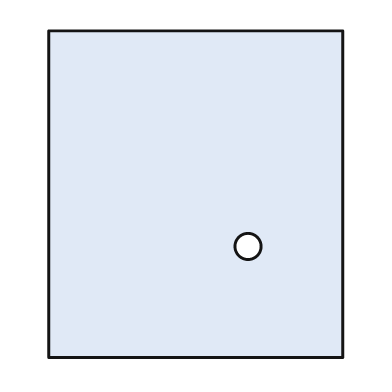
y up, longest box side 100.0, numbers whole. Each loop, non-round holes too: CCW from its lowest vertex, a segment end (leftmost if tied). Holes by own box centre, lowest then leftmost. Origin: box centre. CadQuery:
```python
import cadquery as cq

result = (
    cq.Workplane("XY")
    .moveTo(-45.0, -50.0)
    .lineTo(45.0, -50.0)
    .lineTo(45.0, 50.0)
    .lineTo(-45.0, 50.0)
    .close()
    .moveTo(16.0, -16.0)
    .circle(4.0)
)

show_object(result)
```